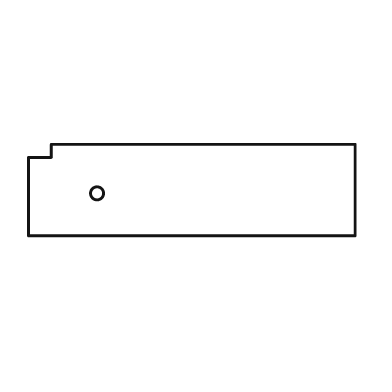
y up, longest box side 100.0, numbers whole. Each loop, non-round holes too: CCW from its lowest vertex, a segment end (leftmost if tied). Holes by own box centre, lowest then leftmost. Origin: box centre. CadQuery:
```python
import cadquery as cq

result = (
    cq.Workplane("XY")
    .moveTo(-50.0, -14.0)
    .lineTo(50.0, -14.0)
    .lineTo(50.0, 14.0)
    .lineTo(-43.0, 14.0)
    .lineTo(-43.0, 10.0)
    .lineTo(-50.0, 10.0)
    .close()
    .moveTo(-29.0, -1.0)
    .circle(2.0)
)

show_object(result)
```